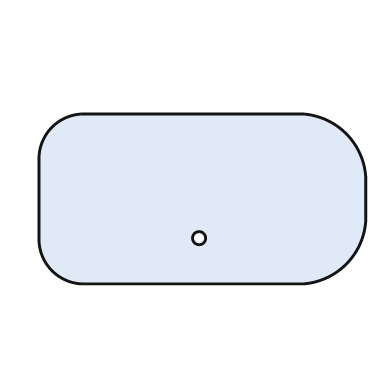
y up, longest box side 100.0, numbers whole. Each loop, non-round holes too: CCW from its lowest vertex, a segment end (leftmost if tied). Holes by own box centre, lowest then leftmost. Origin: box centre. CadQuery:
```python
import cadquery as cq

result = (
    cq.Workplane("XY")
    .moveTo(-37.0, -26.0)
    .lineTo(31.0, -26.0)
    .threePointArc((44.0, -20.0), (50.0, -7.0))
    .lineTo(50.0, 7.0)
    .threePointArc((44.0, 20.0), (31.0, 26.0))
    .lineTo(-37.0, 26.0)
    .threePointArc((-46.0, 22.0), (-50.0, 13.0))
    .lineTo(-50.0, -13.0)
    .threePointArc((-46.0, -22.0), (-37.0, -26.0))
    .close()
    .moveTo(-1.0, -12.0)
    .circle(2.0)
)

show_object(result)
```